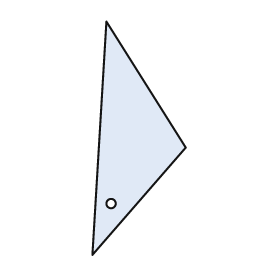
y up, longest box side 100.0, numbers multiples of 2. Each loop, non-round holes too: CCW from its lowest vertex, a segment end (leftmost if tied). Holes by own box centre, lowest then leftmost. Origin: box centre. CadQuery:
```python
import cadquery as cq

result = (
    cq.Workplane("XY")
    .moveTo(-20.0, -50.0)
    .lineTo(20.0, -4.0)
    .lineTo(-14.0, 50.0)
    .close()
    .moveTo(-12.0, -28.0)
    .circle(2.0)
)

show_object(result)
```